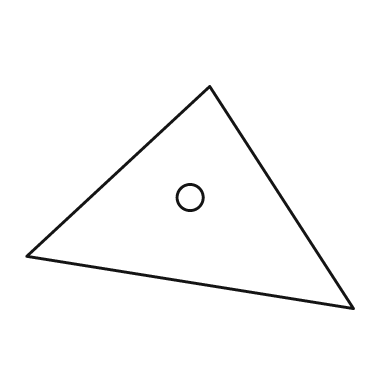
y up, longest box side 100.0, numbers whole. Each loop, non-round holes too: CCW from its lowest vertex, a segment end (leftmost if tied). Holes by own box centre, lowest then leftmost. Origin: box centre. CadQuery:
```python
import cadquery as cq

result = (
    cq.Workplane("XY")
    .moveTo(50.0, -34.0)
    .lineTo(6.0, 34.0)
    .lineTo(-50.0, -18.0)
    .close()
    .moveTo(0.0, 0.0)
    .circle(4.0)
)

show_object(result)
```